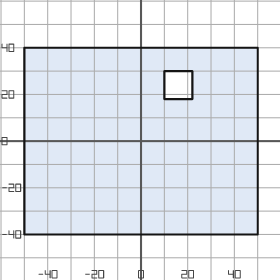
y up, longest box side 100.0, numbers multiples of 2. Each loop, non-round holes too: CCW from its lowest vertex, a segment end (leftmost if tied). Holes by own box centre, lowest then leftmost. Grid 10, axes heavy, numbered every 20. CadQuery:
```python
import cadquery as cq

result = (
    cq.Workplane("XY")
    .moveTo(-50.0, -40.0)
    .lineTo(50.0, -40.0)
    .lineTo(50.0, 40.0)
    .lineTo(-50.0, 40.0)
    .close()
    .moveTo(10.0, 18.0)
    .lineTo(22.0, 18.0)
    .lineTo(22.0, 30.0)
    .lineTo(10.0, 30.0)
    .close()
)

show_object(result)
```